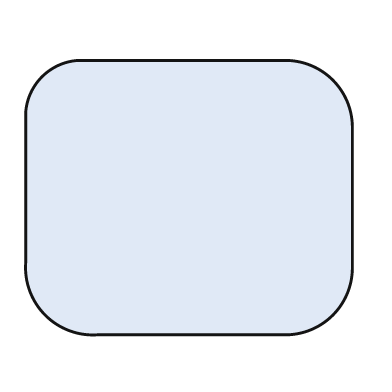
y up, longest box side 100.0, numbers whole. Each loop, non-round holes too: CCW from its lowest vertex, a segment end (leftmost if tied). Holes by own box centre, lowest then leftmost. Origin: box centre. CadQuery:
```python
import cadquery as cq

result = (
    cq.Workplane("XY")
    .moveTo(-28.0, -42.0)
    .lineTo(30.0, -42.0)
    .threePointArc((44.0, -36.0), (50.0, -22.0))
    .lineTo(50.0, 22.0)
    .threePointArc((44.0, 36.0), (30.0, 42.0))
    .lineTo(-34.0, 42.0)
    .threePointArc((-45.0, 37.0), (-50.0, 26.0))
    .lineTo(-50.0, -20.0)
    .threePointArc((-44.0, -36.0), (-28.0, -42.0))
    .close()
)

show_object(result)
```